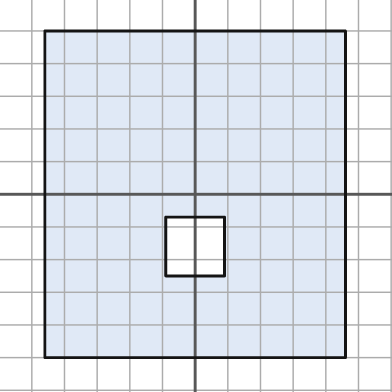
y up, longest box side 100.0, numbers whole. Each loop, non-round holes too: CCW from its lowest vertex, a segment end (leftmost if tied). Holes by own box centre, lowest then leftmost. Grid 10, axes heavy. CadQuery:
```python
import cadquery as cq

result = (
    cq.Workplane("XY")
    .moveTo(-46.0, -50.0)
    .lineTo(46.0, -50.0)
    .lineTo(46.0, 50.0)
    .lineTo(-46.0, 50.0)
    .close()
    .moveTo(-9.0, -25.0)
    .lineTo(9.0, -25.0)
    .lineTo(9.0, -7.0)
    .lineTo(-9.0, -7.0)
    .close()
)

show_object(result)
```